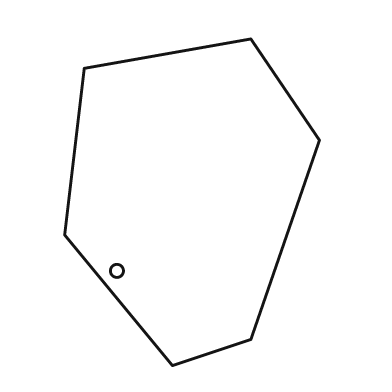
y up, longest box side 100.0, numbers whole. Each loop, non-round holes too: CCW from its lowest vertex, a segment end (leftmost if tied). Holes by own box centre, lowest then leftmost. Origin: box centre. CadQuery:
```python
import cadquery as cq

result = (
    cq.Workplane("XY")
    .moveTo(-6.0, -50.0)
    .lineTo(18.0, -42.0)
    .lineTo(39.0, 19.0)
    .lineTo(18.0, 50.0)
    .lineTo(-33.0, 41.0)
    .lineTo(-39.0, -10.0)
    .close()
    .moveTo(-23.0, -21.0)
    .circle(2.0)
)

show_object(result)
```